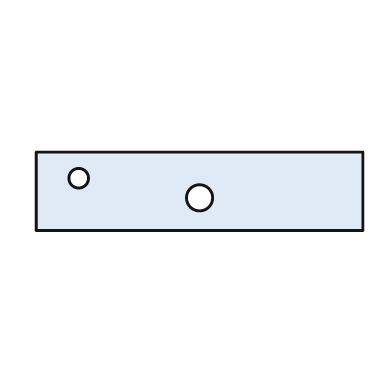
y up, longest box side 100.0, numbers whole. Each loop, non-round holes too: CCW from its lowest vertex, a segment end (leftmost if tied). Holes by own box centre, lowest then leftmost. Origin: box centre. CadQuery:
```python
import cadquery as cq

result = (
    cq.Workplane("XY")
    .moveTo(-50.0, -12.0)
    .lineTo(50.0, -12.0)
    .lineTo(50.0, 12.0)
    .lineTo(-50.0, 12.0)
    .close()
    .moveTo(0.0, -2.0)
    .circle(4.0)
    .moveTo(-37.0, 4.0)
    .circle(3.0)
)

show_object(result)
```